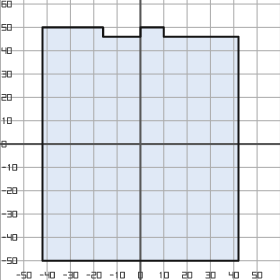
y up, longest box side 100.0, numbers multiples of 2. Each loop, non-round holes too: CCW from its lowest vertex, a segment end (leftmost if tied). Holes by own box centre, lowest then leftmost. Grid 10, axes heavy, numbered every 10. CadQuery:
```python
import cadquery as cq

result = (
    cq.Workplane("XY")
    .moveTo(-42.0, -50.0)
    .lineTo(42.0, -50.0)
    .lineTo(42.0, 46.0)
    .lineTo(10.0, 46.0)
    .lineTo(10.0, 50.0)
    .lineTo(0.0, 50.0)
    .lineTo(0.0, 46.0)
    .lineTo(-16.0, 46.0)
    .lineTo(-16.0, 50.0)
    .lineTo(-42.0, 50.0)
    .close()
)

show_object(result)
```